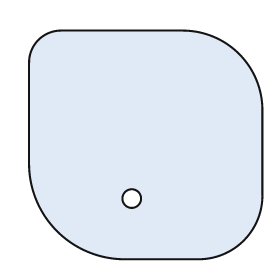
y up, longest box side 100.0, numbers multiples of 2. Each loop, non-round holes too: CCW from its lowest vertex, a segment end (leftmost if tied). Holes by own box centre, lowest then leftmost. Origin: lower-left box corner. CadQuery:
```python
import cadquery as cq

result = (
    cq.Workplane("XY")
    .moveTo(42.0, 0.0)
    .lineTo(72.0, 0.0)
    .threePointArc((92.0, 8.0), (100.0, 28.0))
    .lineTo(100.0, 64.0)
    .threePointArc((90.0, 88.0), (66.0, 98.0))
    .lineTo(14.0, 98.0)
    .threePointArc((4.0, 94.0), (0.0, 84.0))
    .lineTo(0.0, 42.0)
    .threePointArc((12.0, 12.0), (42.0, 0.0))
    .close()
    .moveTo(44.0, 26.0)
    .circle(4.0)
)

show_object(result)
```